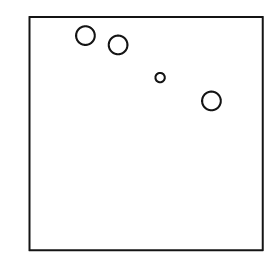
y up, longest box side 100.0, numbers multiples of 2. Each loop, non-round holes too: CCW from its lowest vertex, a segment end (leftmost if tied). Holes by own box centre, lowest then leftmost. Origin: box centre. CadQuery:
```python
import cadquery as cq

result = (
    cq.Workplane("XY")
    .moveTo(-50.0, -50.0)
    .lineTo(50.0, -50.0)
    .lineTo(50.0, 50.0)
    .lineTo(-50.0, 50.0)
    .close()
    .moveTo(28.0, 14.0)
    .circle(4.0)
    .moveTo(6.0, 24.0)
    .circle(2.0)
    .moveTo(-12.0, 38.0)
    .circle(4.0)
    .moveTo(-26.0, 42.0)
    .circle(4.0)
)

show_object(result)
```